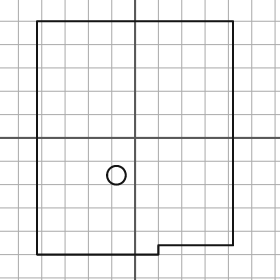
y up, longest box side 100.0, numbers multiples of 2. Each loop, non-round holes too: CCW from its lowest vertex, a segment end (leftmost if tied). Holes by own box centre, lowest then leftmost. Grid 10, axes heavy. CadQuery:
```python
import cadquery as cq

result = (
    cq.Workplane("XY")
    .moveTo(-42.0, -50.0)
    .lineTo(10.0, -50.0)
    .lineTo(10.0, -46.0)
    .lineTo(42.0, -46.0)
    .lineTo(42.0, 50.0)
    .lineTo(-42.0, 50.0)
    .close()
    .moveTo(-8.0, -16.0)
    .circle(4.0)
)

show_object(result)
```